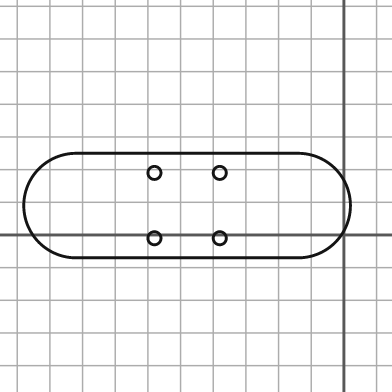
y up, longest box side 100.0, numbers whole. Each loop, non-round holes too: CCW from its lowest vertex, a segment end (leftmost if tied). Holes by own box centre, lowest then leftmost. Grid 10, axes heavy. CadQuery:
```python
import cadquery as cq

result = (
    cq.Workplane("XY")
    .moveTo(-82.0, -7.0)
    .lineTo(-14.0, -7.0)
    .threePointArc((2.0, 9.0), (-14.0, 25.0))
    .lineTo(-82.0, 25.0)
    .threePointArc((-98.0, 9.0), (-82.0, -7.0))
    .close()
    .moveTo(-58.0, -1.0)
    .circle(2.0)
    .moveTo(-38.0, -1.0)
    .circle(2.0)
    .moveTo(-58.0, 19.0)
    .circle(2.0)
    .moveTo(-38.0, 19.0)
    .circle(2.0)
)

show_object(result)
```